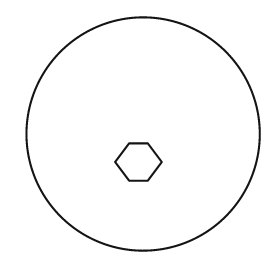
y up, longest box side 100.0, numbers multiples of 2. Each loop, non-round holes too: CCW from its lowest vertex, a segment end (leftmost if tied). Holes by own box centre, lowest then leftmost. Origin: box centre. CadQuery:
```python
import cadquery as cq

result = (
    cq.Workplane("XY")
    .moveTo(0.0, 0.0)
    .circle(50.0)
    .moveTo(-6.0, -20.0)
    .lineTo(2.0, -20.0)
    .lineTo(8.0, -12.0)
    .lineTo(2.0, -4.0)
    .lineTo(-6.0, -4.0)
    .lineTo(-12.0, -12.0)
    .close()
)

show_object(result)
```